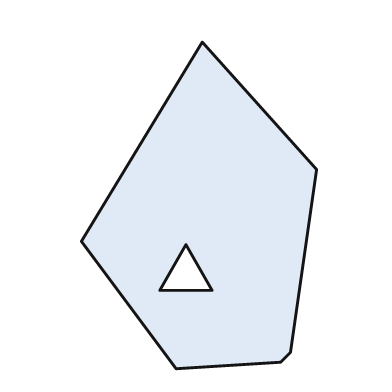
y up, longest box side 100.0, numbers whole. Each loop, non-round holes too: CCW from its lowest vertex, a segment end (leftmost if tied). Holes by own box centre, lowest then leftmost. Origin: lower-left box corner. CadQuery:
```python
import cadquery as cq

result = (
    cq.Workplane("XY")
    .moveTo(29.0, 0.0)
    .lineTo(61.0, 2.0)
    .lineTo(64.0, 5.0)
    .lineTo(72.0, 61.0)
    .lineTo(37.0, 100.0)
    .lineTo(0.0, 39.0)
    .close()
    .moveTo(24.0, 24.0)
    .lineTo(40.0, 24.0)
    .lineTo(32.0, 38.0)
    .close()
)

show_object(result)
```